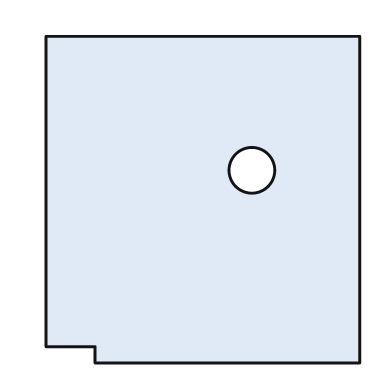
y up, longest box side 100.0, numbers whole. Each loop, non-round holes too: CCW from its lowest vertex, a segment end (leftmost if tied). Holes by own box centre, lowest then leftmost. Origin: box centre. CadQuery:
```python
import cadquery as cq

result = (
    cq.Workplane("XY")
    .moveTo(-33.0, -50.0)
    .lineTo(48.0, -50.0)
    .lineTo(48.0, 50.0)
    .lineTo(-48.0, 50.0)
    .lineTo(-48.0, -45.0)
    .lineTo(-33.0, -45.0)
    .close()
    .moveTo(15.0, 9.0)
    .circle(7.0)
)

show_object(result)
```